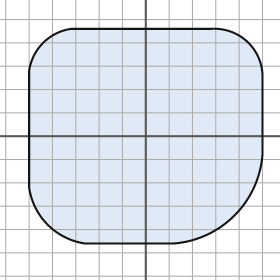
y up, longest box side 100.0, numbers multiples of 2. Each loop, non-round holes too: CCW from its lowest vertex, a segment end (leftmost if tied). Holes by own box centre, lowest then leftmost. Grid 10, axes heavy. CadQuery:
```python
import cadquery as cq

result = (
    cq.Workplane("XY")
    .moveTo(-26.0, -46.0)
    .lineTo(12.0, -46.0)
    .threePointArc((38.0, -34.0), (50.0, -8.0))
    .lineTo(50.0, 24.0)
    .threePointArc((44.0, 40.0), (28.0, 46.0))
    .lineTo(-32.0, 46.0)
    .threePointArc((-44.0, 40.0), (-50.0, 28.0))
    .lineTo(-50.0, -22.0)
    .threePointArc((-42.0, -38.0), (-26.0, -46.0))
    .close()
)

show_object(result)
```